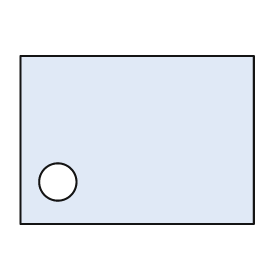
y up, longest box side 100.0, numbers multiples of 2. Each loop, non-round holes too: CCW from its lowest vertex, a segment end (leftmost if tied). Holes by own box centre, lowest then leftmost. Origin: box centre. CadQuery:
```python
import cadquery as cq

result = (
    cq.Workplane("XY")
    .moveTo(-50.0, -36.0)
    .lineTo(50.0, -36.0)
    .lineTo(50.0, 36.0)
    .lineTo(-50.0, 36.0)
    .close()
    .moveTo(-34.0, -18.0)
    .circle(8.0)
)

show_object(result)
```